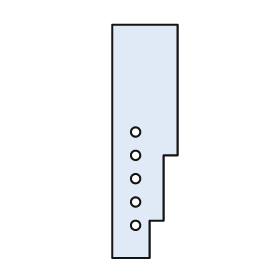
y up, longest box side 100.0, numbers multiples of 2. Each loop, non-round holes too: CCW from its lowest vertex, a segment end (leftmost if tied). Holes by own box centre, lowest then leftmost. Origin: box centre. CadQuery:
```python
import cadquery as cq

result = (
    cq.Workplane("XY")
    .moveTo(-14.0, -50.0)
    .lineTo(2.0, -50.0)
    .lineTo(2.0, -34.0)
    .lineTo(8.0, -34.0)
    .lineTo(8.0, -6.0)
    .lineTo(14.0, -6.0)
    .lineTo(14.0, 50.0)
    .lineTo(-14.0, 50.0)
    .close()
    .moveTo(-4.0, -36.0)
    .circle(2.0)
    .moveTo(-4.0, -26.0)
    .circle(2.0)
    .moveTo(-4.0, -16.0)
    .circle(2.0)
    .moveTo(-4.0, -6.0)
    .circle(2.0)
    .moveTo(-4.0, 4.0)
    .circle(2.0)
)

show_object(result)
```